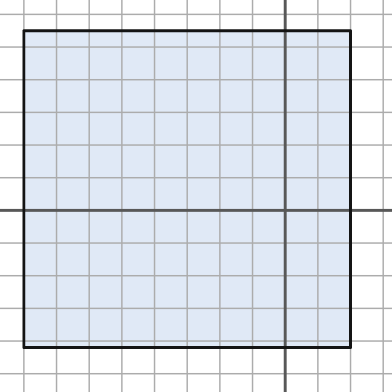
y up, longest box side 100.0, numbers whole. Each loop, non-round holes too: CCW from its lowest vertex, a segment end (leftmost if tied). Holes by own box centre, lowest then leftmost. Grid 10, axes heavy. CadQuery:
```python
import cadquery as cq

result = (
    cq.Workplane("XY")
    .moveTo(-80.0, -42.0)
    .lineTo(20.0, -42.0)
    .lineTo(20.0, 55.0)
    .lineTo(-80.0, 55.0)
    .close()
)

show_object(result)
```